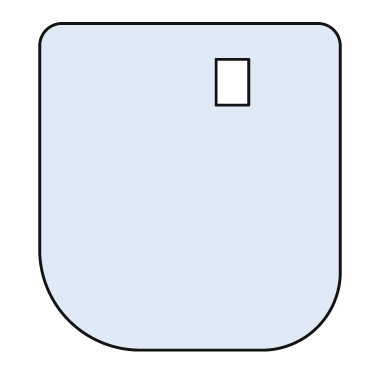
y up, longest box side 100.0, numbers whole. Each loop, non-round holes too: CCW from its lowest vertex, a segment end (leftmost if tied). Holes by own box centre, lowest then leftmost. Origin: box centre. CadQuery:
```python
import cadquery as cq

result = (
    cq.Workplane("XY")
    .moveTo(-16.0, -50.0)
    .lineTo(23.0, -50.0)
    .threePointArc((39.0, -43.0), (46.0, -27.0))
    .lineTo(46.0, 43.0)
    .threePointArc((44.0, 48.0), (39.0, 50.0))
    .lineTo(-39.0, 50.0)
    .threePointArc((-44.0, 48.0), (-46.0, 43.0))
    .lineTo(-46.0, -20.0)
    .threePointArc((-37.0, -41.0), (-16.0, -50.0))
    .close()
    .moveTo(8.0, 25.0)
    .lineTo(18.0, 25.0)
    .lineTo(18.0, 39.0)
    .lineTo(8.0, 39.0)
    .close()
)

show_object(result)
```